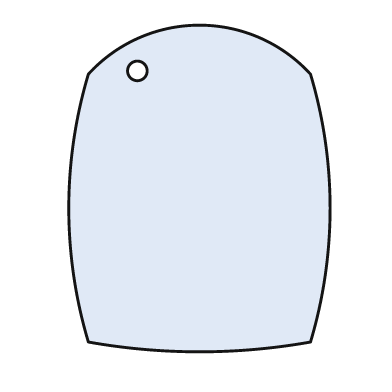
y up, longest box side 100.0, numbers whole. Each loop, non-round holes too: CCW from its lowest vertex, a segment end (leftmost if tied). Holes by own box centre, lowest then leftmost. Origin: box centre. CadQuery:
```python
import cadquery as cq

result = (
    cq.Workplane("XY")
    .moveTo(-34.0, -47.0)
    .threePointArc((0.0, -50.0), (34.0, -47.0))
    .threePointArc((40.0, -6.0), (34.0, 35.0))
    .threePointArc((0.0, 50.0), (-34.0, 35.0))
    .threePointArc((-40.0, -6.0), (-34.0, -47.0))
    .close()
    .moveTo(-19.0, 36.0)
    .circle(3.0)
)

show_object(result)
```